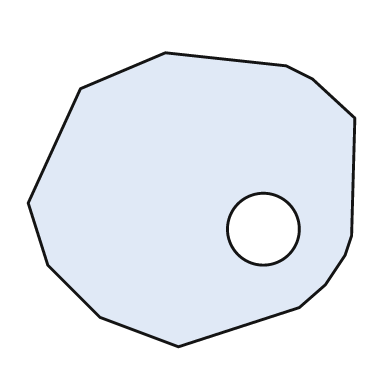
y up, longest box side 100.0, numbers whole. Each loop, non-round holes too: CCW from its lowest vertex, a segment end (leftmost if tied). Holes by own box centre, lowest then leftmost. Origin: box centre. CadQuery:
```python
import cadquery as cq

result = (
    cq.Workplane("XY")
    .moveTo(-4.0, -45.0)
    .lineTo(33.0, -33.0)
    .lineTo(41.0, -26.0)
    .lineTo(47.0, -17.0)
    .lineTo(49.0, -11.0)
    .lineTo(50.0, 25.0)
    .lineTo(37.0, 37.0)
    .lineTo(29.0, 41.0)
    .lineTo(-8.0, 45.0)
    .lineTo(-34.0, 34.0)
    .lineTo(-50.0, -1.0)
    .lineTo(-44.0, -20.0)
    .lineTo(-28.0, -36.0)
    .close()
    .moveTo(22.0, -9.0)
    .circle(11.0)
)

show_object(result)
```